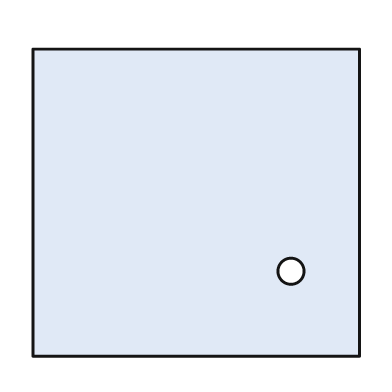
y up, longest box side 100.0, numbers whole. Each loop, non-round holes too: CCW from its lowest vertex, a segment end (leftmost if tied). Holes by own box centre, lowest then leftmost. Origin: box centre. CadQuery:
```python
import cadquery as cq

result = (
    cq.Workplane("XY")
    .moveTo(-50.0, -47.0)
    .lineTo(50.0, -47.0)
    .lineTo(50.0, 47.0)
    .lineTo(-50.0, 47.0)
    .close()
    .moveTo(29.0, -21.0)
    .circle(4.0)
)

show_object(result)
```